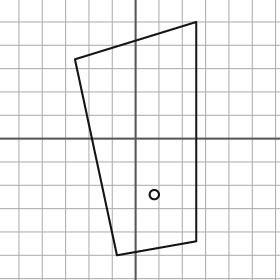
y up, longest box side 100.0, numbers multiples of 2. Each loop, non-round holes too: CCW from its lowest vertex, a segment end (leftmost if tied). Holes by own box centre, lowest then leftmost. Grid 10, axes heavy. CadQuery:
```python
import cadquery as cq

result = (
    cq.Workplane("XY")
    .moveTo(-8.0, -50.0)
    .lineTo(26.0, -44.0)
    .lineTo(26.0, 50.0)
    .lineTo(-26.0, 34.0)
    .close()
    .moveTo(8.0, -24.0)
    .circle(2.0)
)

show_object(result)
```